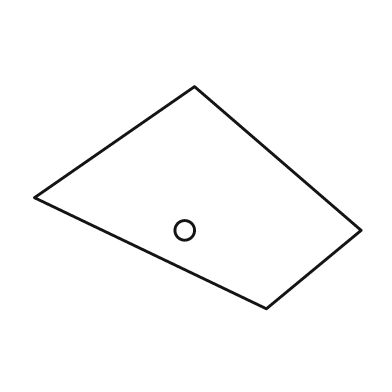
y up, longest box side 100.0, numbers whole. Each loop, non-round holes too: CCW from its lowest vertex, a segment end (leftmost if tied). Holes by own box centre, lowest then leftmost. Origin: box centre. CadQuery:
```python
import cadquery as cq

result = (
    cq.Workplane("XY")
    .moveTo(21.0, -34.0)
    .lineTo(50.0, -10.0)
    .lineTo(-1.0, 34.0)
    .lineTo(-50.0, 0.0)
    .close()
    .moveTo(-4.0, -10.0)
    .circle(3.0)
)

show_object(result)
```